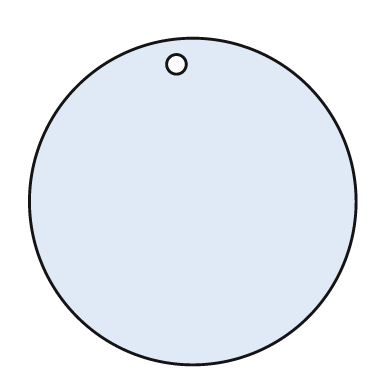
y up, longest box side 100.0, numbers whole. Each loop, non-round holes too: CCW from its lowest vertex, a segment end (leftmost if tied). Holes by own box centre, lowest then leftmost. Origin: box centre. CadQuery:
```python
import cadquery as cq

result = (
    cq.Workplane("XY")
    .moveTo(0.0, 0.0)
    .circle(50.0)
    .moveTo(-5.0, 42.0)
    .circle(3.0)
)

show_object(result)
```